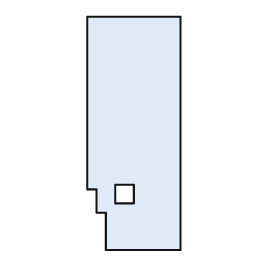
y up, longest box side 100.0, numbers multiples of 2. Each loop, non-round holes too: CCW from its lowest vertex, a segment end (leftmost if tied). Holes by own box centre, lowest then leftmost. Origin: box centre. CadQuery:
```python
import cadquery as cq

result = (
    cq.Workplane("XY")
    .moveTo(-12.0, -50.0)
    .lineTo(20.0, -50.0)
    .lineTo(20.0, 50.0)
    .lineTo(-20.0, 50.0)
    .lineTo(-20.0, -24.0)
    .lineTo(-16.0, -24.0)
    .lineTo(-16.0, -34.0)
    .lineTo(-12.0, -34.0)
    .close()
    .moveTo(-8.0, -30.0)
    .lineTo(0.0, -30.0)
    .lineTo(0.0, -22.0)
    .lineTo(-8.0, -22.0)
    .close()
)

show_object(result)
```